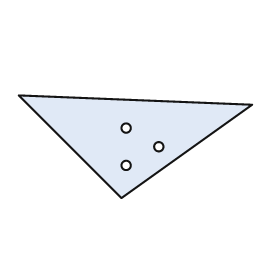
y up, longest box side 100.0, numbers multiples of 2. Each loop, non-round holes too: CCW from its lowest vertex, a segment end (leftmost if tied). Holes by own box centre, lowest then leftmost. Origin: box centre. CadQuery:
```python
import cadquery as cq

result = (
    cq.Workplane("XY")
    .moveTo(-6.0, -22.0)
    .lineTo(50.0, 18.0)
    .lineTo(-50.0, 22.0)
    .close()
    .moveTo(-4.0, -8.0)
    .circle(2.0)
    .moveTo(10.0, 0.0)
    .circle(2.0)
    .moveTo(-4.0, 8.0)
    .circle(2.0)
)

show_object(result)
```